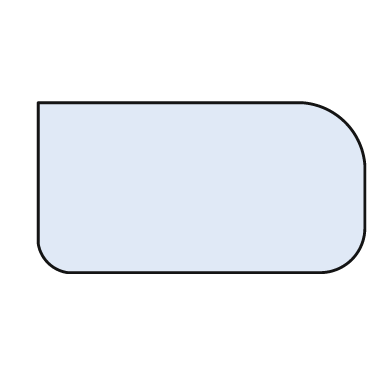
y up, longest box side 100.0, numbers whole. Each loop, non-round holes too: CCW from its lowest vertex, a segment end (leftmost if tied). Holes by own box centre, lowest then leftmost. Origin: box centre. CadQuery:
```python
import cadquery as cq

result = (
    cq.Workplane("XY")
    .moveTo(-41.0, -26.0)
    .lineTo(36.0, -26.0)
    .threePointArc((46.0, -22.0), (50.0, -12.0))
    .lineTo(50.0, 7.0)
    .threePointArc((44.0, 20.0), (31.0, 26.0))
    .lineTo(-50.0, 26.0)
    .lineTo(-50.0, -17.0)
    .threePointArc((-47.0, -23.0), (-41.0, -26.0))
    .close()
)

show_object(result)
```